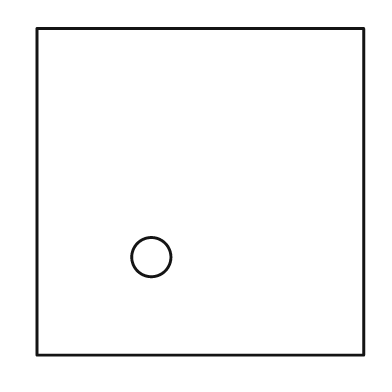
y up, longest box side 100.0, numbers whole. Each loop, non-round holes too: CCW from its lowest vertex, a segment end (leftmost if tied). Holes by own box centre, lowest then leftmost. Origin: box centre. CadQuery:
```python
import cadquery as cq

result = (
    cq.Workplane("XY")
    .moveTo(-50.0, -50.0)
    .lineTo(50.0, -50.0)
    .lineTo(50.0, 50.0)
    .lineTo(-50.0, 50.0)
    .close()
    .moveTo(-15.0, -20.0)
    .circle(6.0)
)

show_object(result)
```